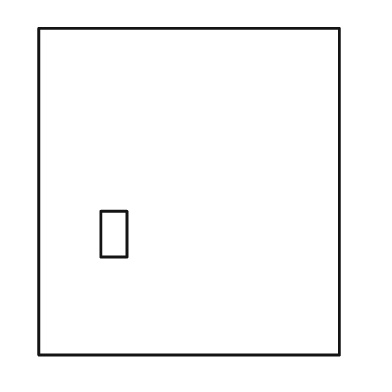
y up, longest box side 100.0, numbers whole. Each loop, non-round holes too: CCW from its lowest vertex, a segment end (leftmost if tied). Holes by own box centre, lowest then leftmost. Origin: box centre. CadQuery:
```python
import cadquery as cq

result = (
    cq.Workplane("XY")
    .moveTo(-46.0, -50.0)
    .lineTo(46.0, -50.0)
    .lineTo(46.0, 50.0)
    .lineTo(-46.0, 50.0)
    .close()
    .moveTo(-27.0, -20.0)
    .lineTo(-19.0, -20.0)
    .lineTo(-19.0, -6.0)
    .lineTo(-27.0, -6.0)
    .close()
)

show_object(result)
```